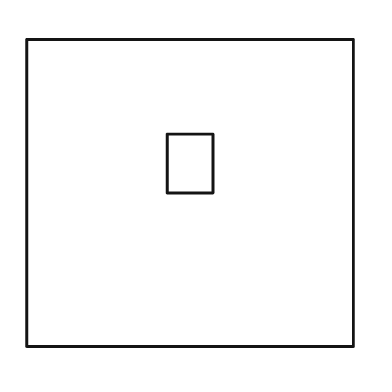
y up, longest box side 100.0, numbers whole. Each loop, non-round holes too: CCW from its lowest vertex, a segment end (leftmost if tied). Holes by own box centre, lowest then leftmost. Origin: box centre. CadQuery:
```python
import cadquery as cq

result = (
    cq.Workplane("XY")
    .moveTo(-50.0, -47.0)
    .lineTo(50.0, -47.0)
    .lineTo(50.0, 47.0)
    .lineTo(-50.0, 47.0)
    .close()
    .moveTo(-7.0, 0.0)
    .lineTo(7.0, 0.0)
    .lineTo(7.0, 18.0)
    .lineTo(-7.0, 18.0)
    .close()
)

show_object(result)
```